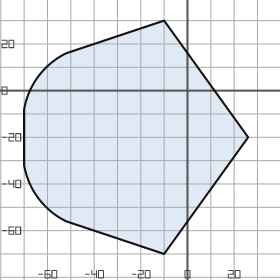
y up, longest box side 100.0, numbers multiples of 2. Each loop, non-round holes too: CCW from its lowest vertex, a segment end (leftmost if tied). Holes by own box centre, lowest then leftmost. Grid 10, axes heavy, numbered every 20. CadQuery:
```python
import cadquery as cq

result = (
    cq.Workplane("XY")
    .moveTo(-10.0, -70.0)
    .lineTo(26.0, -20.0)
    .lineTo(-10.0, 30.0)
    .lineTo(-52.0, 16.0)
    .threePointArc((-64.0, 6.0), (-70.0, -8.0))
    .lineTo(-70.0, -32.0)
    .threePointArc((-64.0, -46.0), (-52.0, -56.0))
    .close()
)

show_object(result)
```